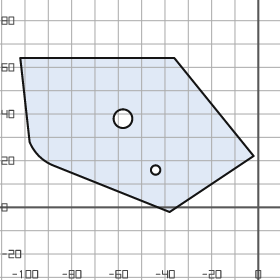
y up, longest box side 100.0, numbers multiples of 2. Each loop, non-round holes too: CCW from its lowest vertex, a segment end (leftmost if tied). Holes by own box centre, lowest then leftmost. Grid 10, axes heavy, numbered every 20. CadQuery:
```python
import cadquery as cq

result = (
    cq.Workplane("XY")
    .moveTo(-38.0, -2.0)
    .lineTo(-2.0, 22.0)
    .lineTo(-36.0, 64.0)
    .lineTo(-102.0, 64.0)
    .lineTo(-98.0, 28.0)
    .threePointArc((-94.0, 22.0), (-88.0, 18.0))
    .close()
    .moveTo(-44.0, 16.0)
    .circle(2.0)
    .moveTo(-58.0, 38.0)
    .circle(4.0)
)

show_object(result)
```